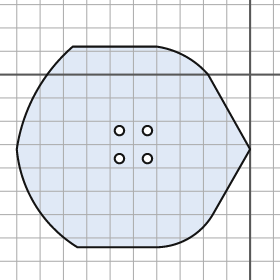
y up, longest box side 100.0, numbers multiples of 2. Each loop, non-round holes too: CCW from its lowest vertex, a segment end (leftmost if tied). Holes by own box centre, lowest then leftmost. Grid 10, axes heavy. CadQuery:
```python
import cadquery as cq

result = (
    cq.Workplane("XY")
    .moveTo(-74.0, -74.0)
    .lineTo(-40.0, -74.0)
    .threePointArc((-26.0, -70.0), (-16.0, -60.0))
    .lineTo(0.0, -32.0)
    .lineTo(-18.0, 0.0)
    .threePointArc((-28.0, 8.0), (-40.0, 12.0))
    .lineTo(-76.0, 12.0)
    .threePointArc((-92.0, -8.0), (-100.0, -32.0))
    .threePointArc((-92.0, -56.0), (-74.0, -74.0))
    .close()
    .moveTo(-56.0, -36.0)
    .circle(2.0)
    .moveTo(-44.0, -36.0)
    .circle(2.0)
    .moveTo(-56.0, -24.0)
    .circle(2.0)
    .moveTo(-44.0, -24.0)
    .circle(2.0)
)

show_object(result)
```